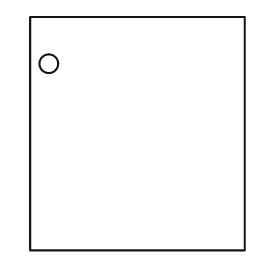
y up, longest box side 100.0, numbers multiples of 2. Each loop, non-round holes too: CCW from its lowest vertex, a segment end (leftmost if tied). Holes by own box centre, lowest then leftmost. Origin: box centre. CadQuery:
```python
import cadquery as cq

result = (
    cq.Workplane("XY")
    .moveTo(-46.0, -50.0)
    .lineTo(46.0, -50.0)
    .lineTo(46.0, 50.0)
    .lineTo(-46.0, 50.0)
    .close()
    .moveTo(-38.0, 30.0)
    .circle(4.0)
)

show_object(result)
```